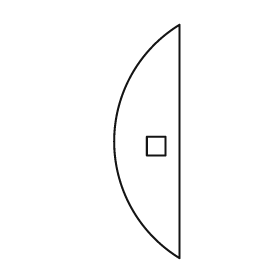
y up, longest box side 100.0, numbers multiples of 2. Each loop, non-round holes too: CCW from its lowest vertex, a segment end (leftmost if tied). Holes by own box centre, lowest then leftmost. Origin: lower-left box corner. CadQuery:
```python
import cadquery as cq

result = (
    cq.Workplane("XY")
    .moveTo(28.0, 0.0)
    .lineTo(28.0, 100.0)
    .threePointArc((0.0, 50.0), (28.0, 0.0))
    .close()
    .moveTo(14.0, 44.0)
    .lineTo(22.0, 44.0)
    .lineTo(22.0, 52.0)
    .lineTo(14.0, 52.0)
    .close()
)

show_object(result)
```